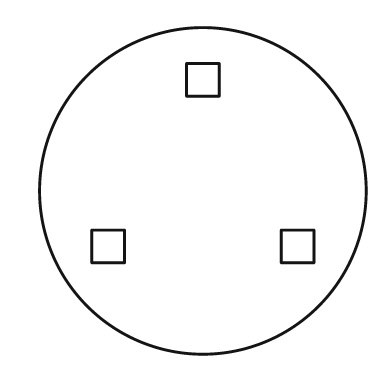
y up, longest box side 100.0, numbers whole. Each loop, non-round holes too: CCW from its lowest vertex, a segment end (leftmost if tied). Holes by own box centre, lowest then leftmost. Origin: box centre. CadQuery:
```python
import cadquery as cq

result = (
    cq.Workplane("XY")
    .moveTo(0.0, 0.0)
    .circle(50.0)
    .moveTo(-34.0, -22.0)
    .lineTo(-24.0, -22.0)
    .lineTo(-24.0, -12.0)
    .lineTo(-34.0, -12.0)
    .close()
    .moveTo(24.0, -22.0)
    .lineTo(34.0, -22.0)
    .lineTo(34.0, -12.0)
    .lineTo(24.0, -12.0)
    .close()
    .moveTo(-5.0, 29.0)
    .lineTo(5.0, 29.0)
    .lineTo(5.0, 39.0)
    .lineTo(-5.0, 39.0)
    .close()
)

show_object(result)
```